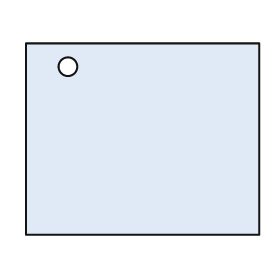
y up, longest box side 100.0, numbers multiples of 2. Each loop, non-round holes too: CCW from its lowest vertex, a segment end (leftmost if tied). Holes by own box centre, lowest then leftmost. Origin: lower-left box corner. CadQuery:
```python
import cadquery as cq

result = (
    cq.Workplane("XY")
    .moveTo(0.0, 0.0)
    .lineTo(100.0, 0.0)
    .lineTo(100.0, 82.0)
    .lineTo(0.0, 82.0)
    .close()
    .moveTo(18.0, 72.0)
    .circle(4.0)
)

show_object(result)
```